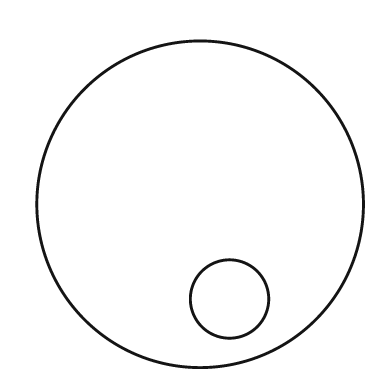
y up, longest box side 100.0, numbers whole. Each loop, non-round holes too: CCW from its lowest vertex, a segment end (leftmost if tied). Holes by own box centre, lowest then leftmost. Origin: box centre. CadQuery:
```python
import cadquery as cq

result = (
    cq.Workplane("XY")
    .moveTo(0.0, 0.0)
    .circle(50.0)
    .moveTo(9.0, -29.0)
    .circle(12.0)
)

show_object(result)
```